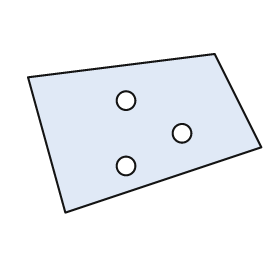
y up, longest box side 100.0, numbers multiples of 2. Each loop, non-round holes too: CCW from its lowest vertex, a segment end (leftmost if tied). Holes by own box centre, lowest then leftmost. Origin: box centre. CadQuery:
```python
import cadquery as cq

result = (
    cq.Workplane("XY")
    .moveTo(-34.0, -34.0)
    .lineTo(50.0, -6.0)
    .lineTo(30.0, 34.0)
    .lineTo(-50.0, 24.0)
    .close()
    .moveTo(-8.0, -14.0)
    .circle(4.0)
    .moveTo(16.0, 0.0)
    .circle(4.0)
    .moveTo(-8.0, 14.0)
    .circle(4.0)
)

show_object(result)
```